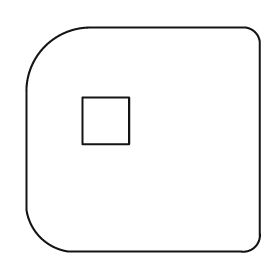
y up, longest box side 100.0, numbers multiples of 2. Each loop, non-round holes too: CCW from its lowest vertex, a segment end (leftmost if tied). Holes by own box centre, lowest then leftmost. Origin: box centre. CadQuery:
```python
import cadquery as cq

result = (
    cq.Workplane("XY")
    .moveTo(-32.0, -48.0)
    .lineTo(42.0, -48.0)
    .threePointArc((48.0, -46.0), (50.0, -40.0))
    .lineTo(50.0, 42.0)
    .threePointArc((48.0, 46.0), (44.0, 48.0))
    .lineTo(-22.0, 48.0)
    .threePointArc((-42.0, 40.0), (-50.0, 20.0))
    .lineTo(-50.0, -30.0)
    .threePointArc((-44.0, -42.0), (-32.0, -48.0))
    .close()
    .moveTo(-26.0, -2.0)
    .lineTo(-6.0, -2.0)
    .lineTo(-6.0, 18.0)
    .lineTo(-26.0, 18.0)
    .close()
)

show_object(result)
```